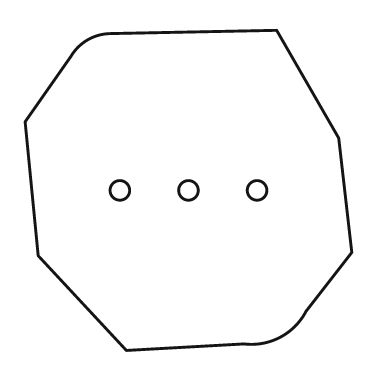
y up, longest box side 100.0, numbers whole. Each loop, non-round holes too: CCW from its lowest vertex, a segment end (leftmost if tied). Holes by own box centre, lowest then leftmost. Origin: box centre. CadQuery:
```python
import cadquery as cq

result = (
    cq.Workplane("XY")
    .moveTo(-19.0, -49.0)
    .lineTo(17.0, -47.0)
    .threePointArc((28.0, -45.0), (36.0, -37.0))
    .lineTo(50.0, -19.0)
    .lineTo(46.0, 16.0)
    .lineTo(27.0, 49.0)
    .lineTo(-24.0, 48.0)
    .threePointArc((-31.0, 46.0), (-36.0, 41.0))
    .lineTo(-50.0, 21.0)
    .lineTo(-46.0, -20.0)
    .close()
    .moveTo(-21.0, 0.0)
    .circle(3.0)
    .moveTo(0.0, 0.0)
    .circle(3.0)
    .moveTo(21.0, 0.0)
    .circle(3.0)
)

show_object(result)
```